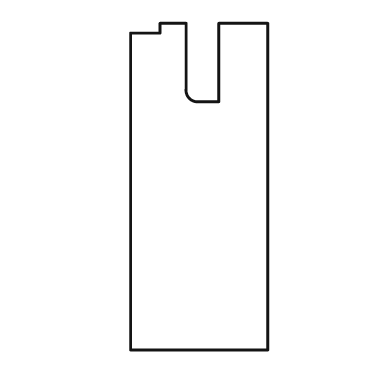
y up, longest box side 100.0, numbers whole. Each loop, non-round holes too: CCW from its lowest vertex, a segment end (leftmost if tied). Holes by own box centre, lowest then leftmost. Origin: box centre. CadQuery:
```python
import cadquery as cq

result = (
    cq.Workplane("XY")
    .moveTo(-21.0, -50.0)
    .lineTo(21.0, -50.0)
    .lineTo(21.0, 50.0)
    .lineTo(6.0, 50.0)
    .lineTo(6.0, 26.0)
    .lineTo(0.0, 26.0)
    .threePointArc((-3.0, 27.0), (-4.0, 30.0))
    .lineTo(-4.0, 50.0)
    .lineTo(-12.0, 50.0)
    .lineTo(-12.0, 47.0)
    .lineTo(-21.0, 47.0)
    .close()
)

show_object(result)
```